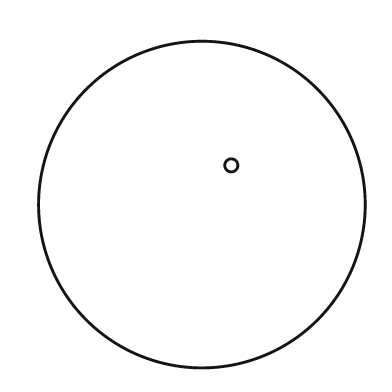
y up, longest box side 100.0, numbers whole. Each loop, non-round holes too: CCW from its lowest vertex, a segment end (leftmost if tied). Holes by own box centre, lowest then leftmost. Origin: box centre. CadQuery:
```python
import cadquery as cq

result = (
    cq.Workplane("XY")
    .moveTo(0.0, 0.0)
    .circle(50.0)
    .moveTo(9.0, 12.0)
    .circle(2.0)
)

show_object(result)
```